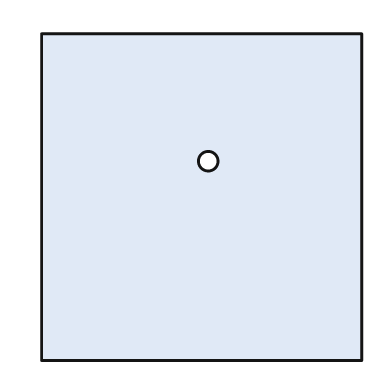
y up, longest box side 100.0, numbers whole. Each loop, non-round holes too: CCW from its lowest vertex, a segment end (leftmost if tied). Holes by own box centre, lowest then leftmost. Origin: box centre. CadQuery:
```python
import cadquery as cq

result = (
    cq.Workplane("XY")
    .moveTo(-49.0, -50.0)
    .lineTo(49.0, -50.0)
    .lineTo(49.0, 50.0)
    .lineTo(-49.0, 50.0)
    .close()
    .moveTo(2.0, 11.0)
    .circle(3.0)
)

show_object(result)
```